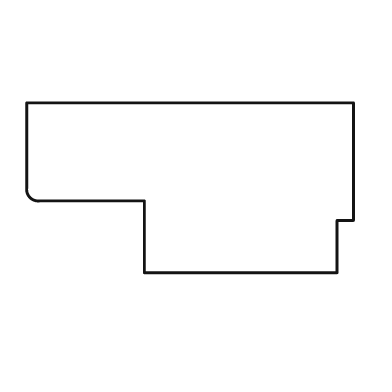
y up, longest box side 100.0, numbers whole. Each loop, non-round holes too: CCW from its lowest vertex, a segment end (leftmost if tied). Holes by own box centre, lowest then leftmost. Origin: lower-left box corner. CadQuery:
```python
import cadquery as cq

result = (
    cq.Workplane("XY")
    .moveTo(36.0, 0.0)
    .lineTo(95.0, 0.0)
    .lineTo(95.0, 16.0)
    .lineTo(100.0, 16.0)
    .lineTo(100.0, 52.0)
    .lineTo(0.0, 52.0)
    .lineTo(0.0, 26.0)
    .threePointArc((1.0, 23.0), (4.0, 22.0))
    .lineTo(36.0, 22.0)
    .close()
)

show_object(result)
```